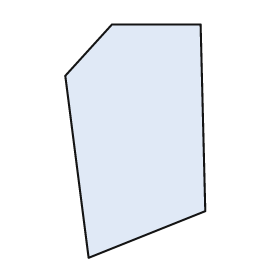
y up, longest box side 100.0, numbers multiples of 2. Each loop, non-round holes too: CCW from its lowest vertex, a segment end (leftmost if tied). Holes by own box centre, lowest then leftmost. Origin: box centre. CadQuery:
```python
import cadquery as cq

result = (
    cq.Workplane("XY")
    .moveTo(-20.0, -50.0)
    .lineTo(30.0, -30.0)
    .lineTo(28.0, 50.0)
    .lineTo(-10.0, 50.0)
    .lineTo(-30.0, 28.0)
    .close()
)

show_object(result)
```